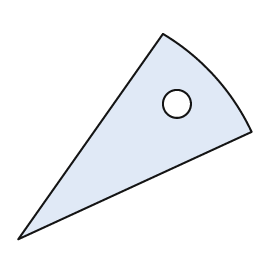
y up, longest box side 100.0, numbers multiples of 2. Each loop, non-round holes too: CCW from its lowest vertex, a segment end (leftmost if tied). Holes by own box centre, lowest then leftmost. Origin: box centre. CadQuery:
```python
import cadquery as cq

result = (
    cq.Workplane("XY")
    .moveTo(-50.0, -44.0)
    .lineTo(50.0, 2.0)
    .threePointArc((34.0, 26.0), (12.0, 44.0))
    .close()
    .moveTo(18.0, 14.0)
    .circle(6.0)
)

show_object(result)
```